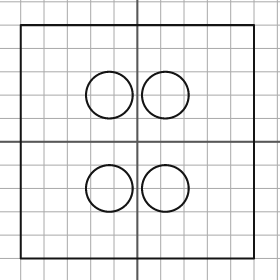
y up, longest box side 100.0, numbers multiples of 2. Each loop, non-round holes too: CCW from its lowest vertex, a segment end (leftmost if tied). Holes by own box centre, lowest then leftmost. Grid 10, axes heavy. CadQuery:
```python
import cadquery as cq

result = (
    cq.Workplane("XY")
    .moveTo(-50.0, -50.0)
    .lineTo(50.0, -50.0)
    .lineTo(50.0, 50.0)
    .lineTo(-50.0, 50.0)
    .close()
    .moveTo(-12.0, -20.0)
    .circle(10.0)
    .moveTo(12.0, -20.0)
    .circle(10.0)
    .moveTo(-12.0, 20.0)
    .circle(10.0)
    .moveTo(12.0, 20.0)
    .circle(10.0)
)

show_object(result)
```